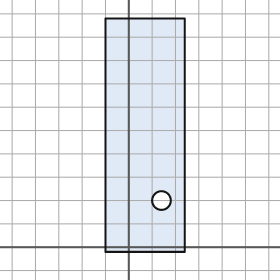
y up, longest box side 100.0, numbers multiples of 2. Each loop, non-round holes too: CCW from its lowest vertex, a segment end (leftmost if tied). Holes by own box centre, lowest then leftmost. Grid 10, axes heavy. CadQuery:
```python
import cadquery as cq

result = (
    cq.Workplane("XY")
    .moveTo(-10.0, -2.0)
    .lineTo(24.0, -2.0)
    .lineTo(24.0, 98.0)
    .lineTo(-10.0, 98.0)
    .close()
    .moveTo(14.0, 20.0)
    .circle(4.0)
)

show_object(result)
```